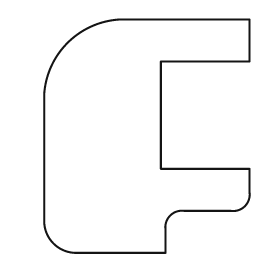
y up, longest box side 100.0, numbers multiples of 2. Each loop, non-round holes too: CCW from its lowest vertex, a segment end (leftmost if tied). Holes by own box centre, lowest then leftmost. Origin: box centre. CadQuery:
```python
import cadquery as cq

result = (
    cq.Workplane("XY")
    .moveTo(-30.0, -50.0)
    .lineTo(8.0, -50.0)
    .lineTo(8.0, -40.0)
    .threePointArc((10.0, -34.0), (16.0, -32.0))
    .lineTo(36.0, -32.0)
    .threePointArc((42.0, -30.0), (44.0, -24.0))
    .lineTo(44.0, -14.0)
    .lineTo(6.0, -14.0)
    .lineTo(6.0, 32.0)
    .lineTo(44.0, 32.0)
    .lineTo(44.0, 50.0)
    .lineTo(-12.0, 50.0)
    .threePointArc((-34.0, 40.0), (-44.0, 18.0))
    .lineTo(-44.0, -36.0)
    .threePointArc((-40.0, -46.0), (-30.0, -50.0))
    .close()
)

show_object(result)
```